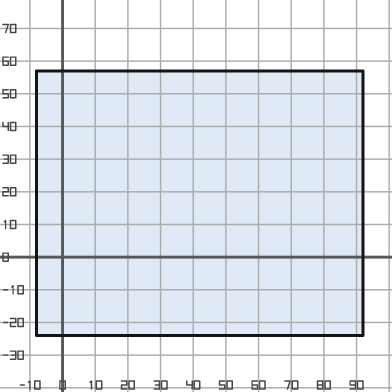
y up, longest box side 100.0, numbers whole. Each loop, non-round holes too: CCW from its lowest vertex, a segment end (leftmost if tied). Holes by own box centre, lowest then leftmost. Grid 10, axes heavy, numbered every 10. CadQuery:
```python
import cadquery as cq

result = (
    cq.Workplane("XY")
    .moveTo(-8.0, -24.0)
    .lineTo(92.0, -24.0)
    .lineTo(92.0, 57.0)
    .lineTo(-8.0, 57.0)
    .close()
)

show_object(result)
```